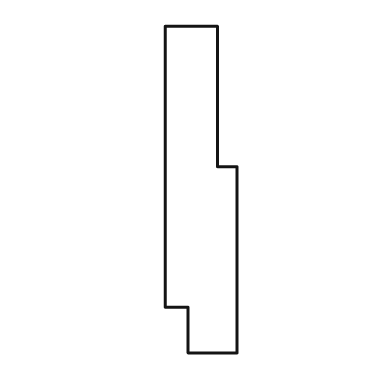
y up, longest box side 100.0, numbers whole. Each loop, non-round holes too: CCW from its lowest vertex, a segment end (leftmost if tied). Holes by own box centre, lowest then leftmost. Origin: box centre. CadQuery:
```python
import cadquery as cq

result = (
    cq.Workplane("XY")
    .moveTo(-4.0, -50.0)
    .lineTo(11.0, -50.0)
    .lineTo(11.0, 7.0)
    .lineTo(5.0, 7.0)
    .lineTo(5.0, 50.0)
    .lineTo(-11.0, 50.0)
    .lineTo(-11.0, -36.0)
    .lineTo(-4.0, -36.0)
    .close()
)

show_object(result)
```